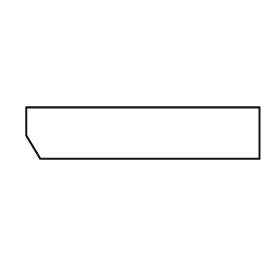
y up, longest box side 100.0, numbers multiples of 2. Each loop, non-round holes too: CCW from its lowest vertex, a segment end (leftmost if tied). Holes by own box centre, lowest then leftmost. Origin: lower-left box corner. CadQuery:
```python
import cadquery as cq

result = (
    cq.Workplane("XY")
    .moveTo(6.0, 0.0)
    .lineTo(100.0, 0.0)
    .lineTo(100.0, 22.0)
    .lineTo(0.0, 22.0)
    .lineTo(0.0, 10.0)
    .close()
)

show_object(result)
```